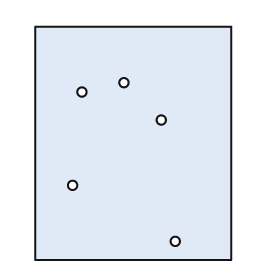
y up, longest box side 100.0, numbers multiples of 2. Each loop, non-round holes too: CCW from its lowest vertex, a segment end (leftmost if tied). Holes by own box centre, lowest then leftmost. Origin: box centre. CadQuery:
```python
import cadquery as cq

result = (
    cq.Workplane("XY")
    .moveTo(-42.0, -50.0)
    .lineTo(42.0, -50.0)
    .lineTo(42.0, 50.0)
    .lineTo(-42.0, 50.0)
    .close()
    .moveTo(18.0, -42.0)
    .circle(2.0)
    .moveTo(-26.0, -18.0)
    .circle(2.0)
    .moveTo(12.0, 10.0)
    .circle(2.0)
    .moveTo(-22.0, 22.0)
    .circle(2.0)
    .moveTo(-4.0, 26.0)
    .circle(2.0)
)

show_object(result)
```